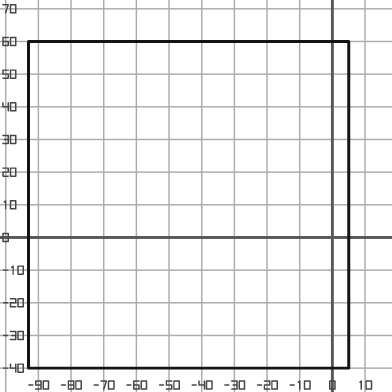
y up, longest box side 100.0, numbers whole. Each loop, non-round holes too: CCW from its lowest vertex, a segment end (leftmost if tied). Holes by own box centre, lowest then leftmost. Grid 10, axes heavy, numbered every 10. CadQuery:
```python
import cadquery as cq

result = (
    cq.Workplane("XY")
    .moveTo(-93.0, -40.0)
    .lineTo(5.0, -40.0)
    .lineTo(5.0, 60.0)
    .lineTo(-93.0, 60.0)
    .close()
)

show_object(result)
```